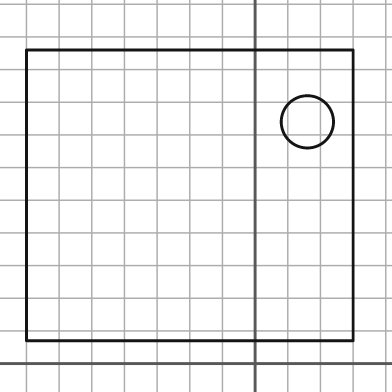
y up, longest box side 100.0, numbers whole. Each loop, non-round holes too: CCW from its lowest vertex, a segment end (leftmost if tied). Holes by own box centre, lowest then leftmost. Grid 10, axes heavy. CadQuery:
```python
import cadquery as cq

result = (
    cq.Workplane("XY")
    .moveTo(-70.0, 7.0)
    .lineTo(30.0, 7.0)
    .lineTo(30.0, 96.0)
    .lineTo(-70.0, 96.0)
    .close()
    .moveTo(16.0, 74.0)
    .circle(8.0)
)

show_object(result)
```